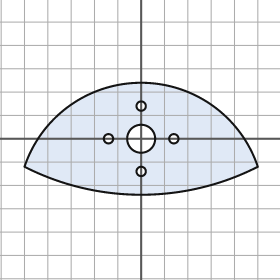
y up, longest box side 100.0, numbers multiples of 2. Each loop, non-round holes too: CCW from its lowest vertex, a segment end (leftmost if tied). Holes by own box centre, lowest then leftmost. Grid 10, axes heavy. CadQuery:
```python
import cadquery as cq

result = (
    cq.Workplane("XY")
    .moveTo(-50.0, -12.0)
    .threePointArc((0.0, -24.0), (50.0, -12.0))
    .threePointArc((0.0, 24.0), (-50.0, -12.0))
    .close()
    .moveTo(0.0, -14.0)
    .circle(2.0)
    .moveTo(-14.0, 0.0)
    .circle(2.0)
    .moveTo(0.0, 0.0)
    .circle(6.0)
    .moveTo(14.0, 0.0)
    .circle(2.0)
    .moveTo(0.0, 14.0)
    .circle(2.0)
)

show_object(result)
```